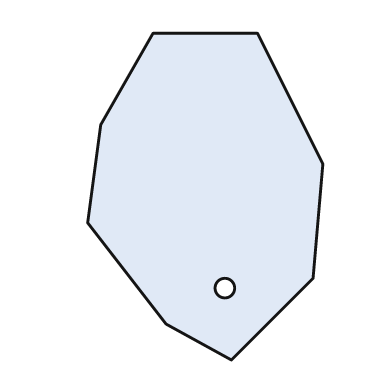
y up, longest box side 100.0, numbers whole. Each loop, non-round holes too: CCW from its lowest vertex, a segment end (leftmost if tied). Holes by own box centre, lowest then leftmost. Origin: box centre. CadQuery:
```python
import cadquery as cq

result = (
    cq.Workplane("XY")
    .moveTo(8.0, -50.0)
    .lineTo(33.0, -25.0)
    .lineTo(36.0, 10.0)
    .lineTo(16.0, 50.0)
    .lineTo(-16.0, 50.0)
    .lineTo(-32.0, 22.0)
    .lineTo(-36.0, -8.0)
    .lineTo(-12.0, -39.0)
    .close()
    .moveTo(6.0, -28.0)
    .circle(3.0)
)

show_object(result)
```